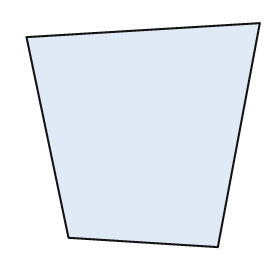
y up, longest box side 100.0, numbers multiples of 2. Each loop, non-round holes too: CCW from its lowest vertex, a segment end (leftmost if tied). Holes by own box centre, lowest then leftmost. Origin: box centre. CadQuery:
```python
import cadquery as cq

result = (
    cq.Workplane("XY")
    .moveTo(32.0, -48.0)
    .lineTo(50.0, 48.0)
    .lineTo(-50.0, 42.0)
    .lineTo(-32.0, -44.0)
    .close()
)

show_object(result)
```